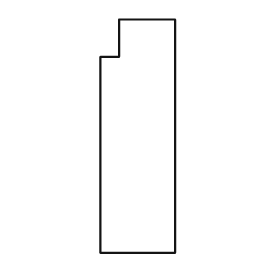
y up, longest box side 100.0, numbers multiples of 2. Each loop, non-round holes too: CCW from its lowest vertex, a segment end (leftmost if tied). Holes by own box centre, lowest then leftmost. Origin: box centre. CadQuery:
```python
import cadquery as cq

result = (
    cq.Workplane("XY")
    .moveTo(-16.0, -50.0)
    .lineTo(16.0, -50.0)
    .lineTo(16.0, 50.0)
    .lineTo(-8.0, 50.0)
    .lineTo(-8.0, 34.0)
    .lineTo(-16.0, 34.0)
    .close()
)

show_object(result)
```